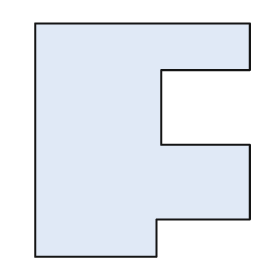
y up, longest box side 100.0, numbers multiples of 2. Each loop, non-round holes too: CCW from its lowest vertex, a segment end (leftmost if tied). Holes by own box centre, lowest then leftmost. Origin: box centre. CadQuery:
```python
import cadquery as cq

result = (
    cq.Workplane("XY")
    .moveTo(-46.0, -50.0)
    .lineTo(6.0, -50.0)
    .lineTo(6.0, -34.0)
    .lineTo(46.0, -34.0)
    .lineTo(46.0, -2.0)
    .lineTo(8.0, -2.0)
    .lineTo(8.0, 30.0)
    .lineTo(46.0, 30.0)
    .lineTo(46.0, 50.0)
    .lineTo(-46.0, 50.0)
    .close()
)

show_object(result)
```